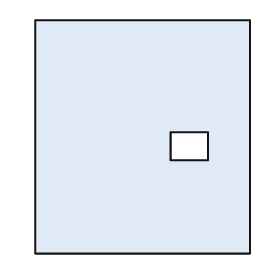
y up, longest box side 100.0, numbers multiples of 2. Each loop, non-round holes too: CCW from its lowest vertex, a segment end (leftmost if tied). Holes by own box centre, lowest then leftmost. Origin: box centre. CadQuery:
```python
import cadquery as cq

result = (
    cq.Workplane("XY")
    .moveTo(-46.0, -50.0)
    .lineTo(46.0, -50.0)
    .lineTo(46.0, 50.0)
    .lineTo(-46.0, 50.0)
    .close()
    .moveTo(12.0, -10.0)
    .lineTo(28.0, -10.0)
    .lineTo(28.0, 2.0)
    .lineTo(12.0, 2.0)
    .close()
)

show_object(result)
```